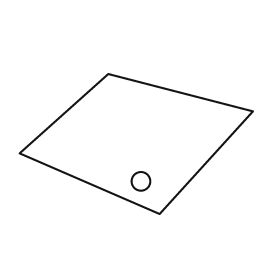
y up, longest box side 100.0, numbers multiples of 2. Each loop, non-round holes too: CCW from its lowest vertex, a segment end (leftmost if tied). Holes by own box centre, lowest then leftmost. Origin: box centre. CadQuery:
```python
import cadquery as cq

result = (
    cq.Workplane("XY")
    .moveTo(10.0, -30.0)
    .lineTo(50.0, 14.0)
    .lineTo(-12.0, 30.0)
    .lineTo(-50.0, -4.0)
    .close()
    .moveTo(2.0, -16.0)
    .circle(4.0)
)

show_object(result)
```